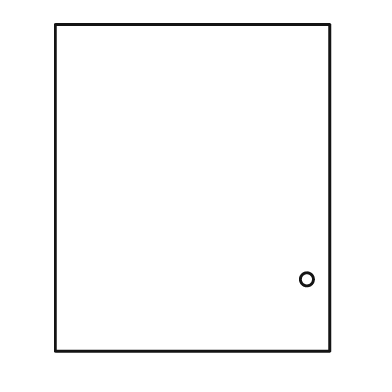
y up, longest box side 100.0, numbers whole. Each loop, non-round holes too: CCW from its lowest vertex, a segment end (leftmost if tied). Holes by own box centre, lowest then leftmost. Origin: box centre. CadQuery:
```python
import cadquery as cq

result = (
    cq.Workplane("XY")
    .moveTo(-42.0, -50.0)
    .lineTo(42.0, -50.0)
    .lineTo(42.0, 50.0)
    .lineTo(-42.0, 50.0)
    .close()
    .moveTo(35.0, -28.0)
    .circle(2.0)
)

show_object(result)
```